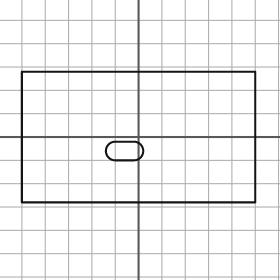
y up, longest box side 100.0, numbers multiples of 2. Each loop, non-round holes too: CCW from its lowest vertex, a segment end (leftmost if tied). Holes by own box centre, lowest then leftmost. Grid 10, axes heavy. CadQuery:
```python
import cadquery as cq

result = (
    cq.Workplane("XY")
    .moveTo(-50.0, -28.0)
    .lineTo(50.0, -28.0)
    .lineTo(50.0, 28.0)
    .lineTo(-50.0, 28.0)
    .close()
    .moveTo(-10.0, -10.0)
    .lineTo(-2.0, -10.0)
    .threePointArc((2.0, -6.0), (-2.0, -2.0))
    .lineTo(-10.0, -2.0)
    .threePointArc((-14.0, -6.0), (-10.0, -10.0))
    .close()
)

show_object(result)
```